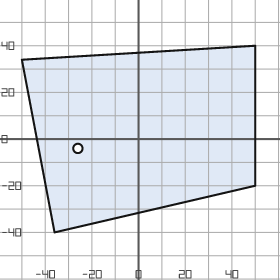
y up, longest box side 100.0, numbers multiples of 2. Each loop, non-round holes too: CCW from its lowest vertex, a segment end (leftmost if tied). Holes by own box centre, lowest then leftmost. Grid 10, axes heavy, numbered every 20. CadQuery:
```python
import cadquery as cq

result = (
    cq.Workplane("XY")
    .moveTo(-36.0, -40.0)
    .lineTo(50.0, -20.0)
    .lineTo(50.0, 40.0)
    .lineTo(-50.0, 34.0)
    .close()
    .moveTo(-26.0, -4.0)
    .circle(2.0)
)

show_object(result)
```